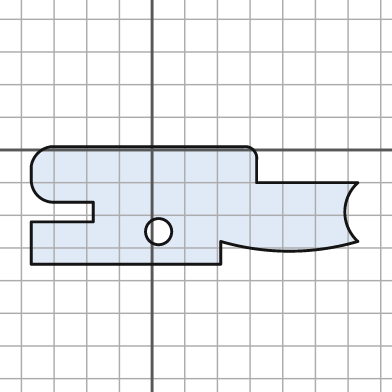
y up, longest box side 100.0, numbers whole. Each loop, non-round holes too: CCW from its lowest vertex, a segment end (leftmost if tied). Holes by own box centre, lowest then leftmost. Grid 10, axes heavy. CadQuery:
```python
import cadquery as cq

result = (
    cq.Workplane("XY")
    .moveTo(-37.0, -35.0)
    .lineTo(21.0, -35.0)
    .lineTo(21.0, -28.0)
    .threePointArc((42.0, -31.0), (63.0, -28.0))
    .threePointArc((59.0, -19.0), (63.0, -10.0))
    .lineTo(32.0, -10.0)
    .lineTo(32.0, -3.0)
    .threePointArc((31.0, 0.0), (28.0, 1.0))
    .lineTo(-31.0, 1.0)
    .threePointArc((-35.0, -1.0), (-37.0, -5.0))
    .lineTo(-37.0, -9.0)
    .threePointArc((-35.0, -14.0), (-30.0, -16.0))
    .lineTo(-18.0, -16.0)
    .lineTo(-18.0, -22.0)
    .lineTo(-37.0, -22.0)
    .close()
    .moveTo(2.0, -25.0)
    .circle(4.0)
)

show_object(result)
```